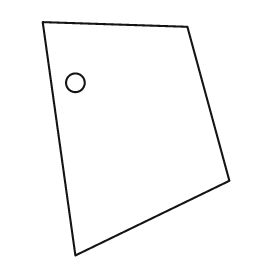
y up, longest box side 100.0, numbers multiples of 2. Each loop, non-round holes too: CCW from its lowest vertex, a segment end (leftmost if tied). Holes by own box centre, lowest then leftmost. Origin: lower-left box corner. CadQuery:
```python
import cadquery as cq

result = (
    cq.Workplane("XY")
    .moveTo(14.0, 0.0)
    .lineTo(80.0, 32.0)
    .lineTo(62.0, 98.0)
    .lineTo(0.0, 100.0)
    .close()
    .moveTo(14.0, 74.0)
    .circle(4.0)
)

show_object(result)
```